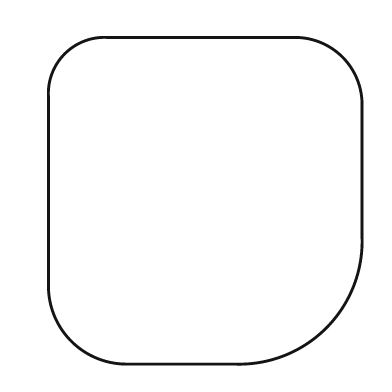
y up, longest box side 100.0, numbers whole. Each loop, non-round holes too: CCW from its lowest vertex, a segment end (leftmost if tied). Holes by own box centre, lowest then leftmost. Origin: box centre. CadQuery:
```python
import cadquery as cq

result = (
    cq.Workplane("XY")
    .moveTo(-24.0, -50.0)
    .lineTo(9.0, -50.0)
    .threePointArc((37.0, -39.0), (48.0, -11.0))
    .lineTo(48.0, 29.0)
    .threePointArc((42.0, 44.0), (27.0, 50.0))
    .lineTo(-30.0, 50.0)
    .threePointArc((-43.0, 45.0), (-48.0, 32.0))
    .lineTo(-48.0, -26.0)
    .threePointArc((-41.0, -43.0), (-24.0, -50.0))
    .close()
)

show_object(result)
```